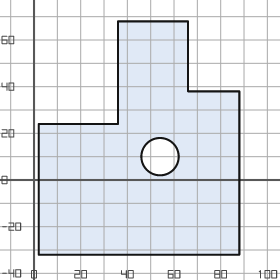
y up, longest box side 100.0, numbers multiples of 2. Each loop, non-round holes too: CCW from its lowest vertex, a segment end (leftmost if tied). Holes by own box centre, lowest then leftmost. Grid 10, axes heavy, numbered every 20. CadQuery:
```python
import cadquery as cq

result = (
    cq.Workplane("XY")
    .moveTo(2.0, -32.0)
    .lineTo(88.0, -32.0)
    .lineTo(88.0, 38.0)
    .lineTo(66.0, 38.0)
    .lineTo(66.0, 68.0)
    .lineTo(36.0, 68.0)
    .lineTo(36.0, 24.0)
    .lineTo(2.0, 24.0)
    .close()
    .moveTo(54.0, 10.0)
    .circle(8.0)
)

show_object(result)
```